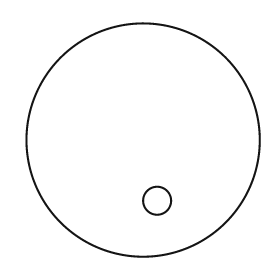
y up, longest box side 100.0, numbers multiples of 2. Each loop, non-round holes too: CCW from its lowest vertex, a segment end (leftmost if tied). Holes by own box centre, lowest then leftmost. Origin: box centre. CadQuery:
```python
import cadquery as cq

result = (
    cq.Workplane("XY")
    .moveTo(0.0, 0.0)
    .circle(50.0)
    .moveTo(6.0, -26.0)
    .circle(6.0)
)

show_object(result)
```